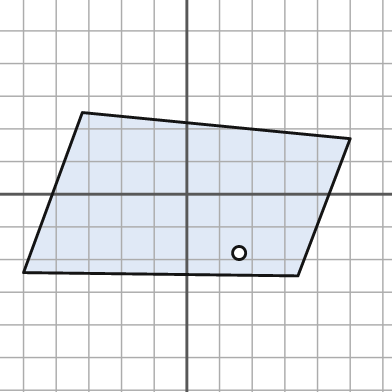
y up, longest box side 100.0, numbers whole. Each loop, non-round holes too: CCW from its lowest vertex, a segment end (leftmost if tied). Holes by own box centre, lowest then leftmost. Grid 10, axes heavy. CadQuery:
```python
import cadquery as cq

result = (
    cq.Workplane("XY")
    .moveTo(34.0, -25.0)
    .lineTo(50.0, 17.0)
    .lineTo(-32.0, 25.0)
    .lineTo(-50.0, -24.0)
    .close()
    .moveTo(16.0, -18.0)
    .circle(2.0)
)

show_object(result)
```